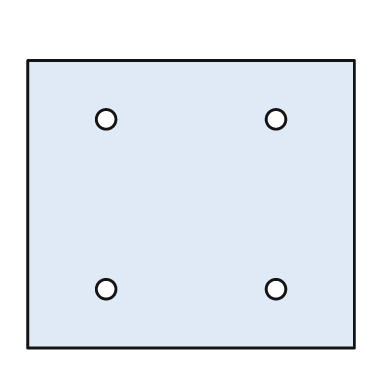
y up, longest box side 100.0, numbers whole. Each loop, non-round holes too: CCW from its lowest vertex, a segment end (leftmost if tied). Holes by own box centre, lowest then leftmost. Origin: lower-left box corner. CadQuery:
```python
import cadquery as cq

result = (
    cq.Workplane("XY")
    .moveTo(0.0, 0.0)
    .lineTo(100.0, 0.0)
    .lineTo(100.0, 88.0)
    .lineTo(0.0, 88.0)
    .close()
    .moveTo(24.0, 18.0)
    .circle(3.0)
    .moveTo(76.0, 18.0)
    .circle(3.0)
    .moveTo(24.0, 70.0)
    .circle(3.0)
    .moveTo(76.0, 70.0)
    .circle(3.0)
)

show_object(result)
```